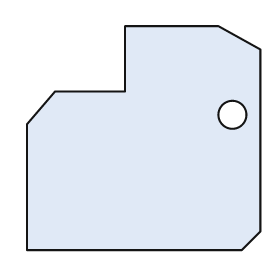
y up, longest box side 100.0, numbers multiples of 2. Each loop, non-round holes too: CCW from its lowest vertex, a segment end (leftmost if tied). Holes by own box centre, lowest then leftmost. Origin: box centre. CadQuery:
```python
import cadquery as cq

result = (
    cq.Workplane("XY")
    .moveTo(-50.0, -48.0)
    .lineTo(42.0, -48.0)
    .lineTo(50.0, -40.0)
    .lineTo(50.0, 38.0)
    .lineTo(32.0, 48.0)
    .lineTo(-8.0, 48.0)
    .lineTo(-8.0, 20.0)
    .lineTo(-38.0, 20.0)
    .lineTo(-50.0, 6.0)
    .close()
    .moveTo(38.0, 10.0)
    .circle(6.0)
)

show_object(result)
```